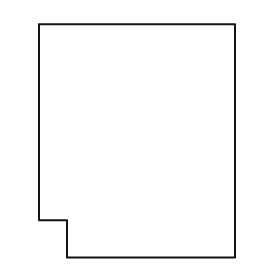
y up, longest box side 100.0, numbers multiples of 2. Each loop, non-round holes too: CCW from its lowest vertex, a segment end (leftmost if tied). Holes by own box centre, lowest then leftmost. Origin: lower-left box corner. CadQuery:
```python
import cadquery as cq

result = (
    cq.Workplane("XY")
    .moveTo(12.0, 0.0)
    .lineTo(84.0, 0.0)
    .lineTo(84.0, 100.0)
    .lineTo(0.0, 100.0)
    .lineTo(0.0, 16.0)
    .lineTo(12.0, 16.0)
    .close()
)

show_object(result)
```